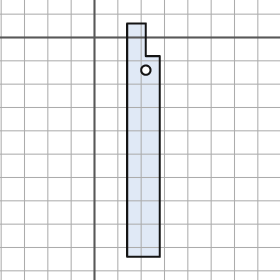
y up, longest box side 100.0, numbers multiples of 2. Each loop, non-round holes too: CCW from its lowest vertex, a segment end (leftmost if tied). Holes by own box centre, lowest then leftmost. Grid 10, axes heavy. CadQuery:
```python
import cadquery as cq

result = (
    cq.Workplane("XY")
    .moveTo(14.0, -94.0)
    .lineTo(28.0, -94.0)
    .lineTo(28.0, -8.0)
    .lineTo(22.0, -8.0)
    .lineTo(22.0, 6.0)
    .lineTo(14.0, 6.0)
    .close()
    .moveTo(22.0, -14.0)
    .circle(2.0)
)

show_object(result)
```